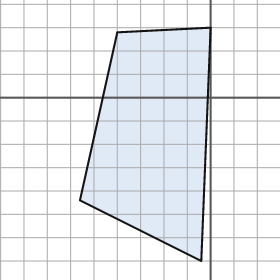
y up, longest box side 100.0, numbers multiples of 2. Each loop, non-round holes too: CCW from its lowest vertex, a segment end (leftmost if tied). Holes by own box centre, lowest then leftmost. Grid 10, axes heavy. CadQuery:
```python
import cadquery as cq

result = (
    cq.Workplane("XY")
    .moveTo(-4.0, -70.0)
    .lineTo(0.0, 30.0)
    .lineTo(-40.0, 28.0)
    .lineTo(-56.0, -44.0)
    .close()
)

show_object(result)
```